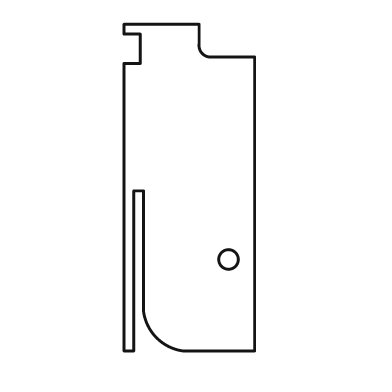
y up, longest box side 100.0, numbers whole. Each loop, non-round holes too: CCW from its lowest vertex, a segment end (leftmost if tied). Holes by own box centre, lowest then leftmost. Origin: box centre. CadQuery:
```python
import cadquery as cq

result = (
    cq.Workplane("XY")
    .moveTo(-20.0, -50.0)
    .lineTo(-17.0, -50.0)
    .lineTo(-17.0, -1.0)
    .lineTo(-14.0, -1.0)
    .lineTo(-14.0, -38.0)
    .threePointArc((-10.0, -46.0), (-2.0, -50.0))
    .lineTo(20.0, -50.0)
    .lineTo(20.0, 40.0)
    .lineTo(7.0, 40.0)
    .threePointArc((4.0, 41.0), (3.0, 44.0))
    .lineTo(3.0, 50.0)
    .lineTo(-20.0, 50.0)
    .lineTo(-20.0, 47.0)
    .lineTo(-15.0, 47.0)
    .lineTo(-15.0, 38.0)
    .lineTo(-20.0, 38.0)
    .close()
    .moveTo(12.0, -22.0)
    .circle(3.0)
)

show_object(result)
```